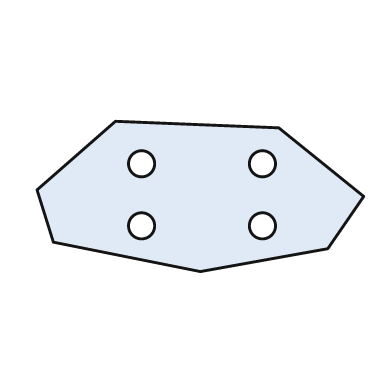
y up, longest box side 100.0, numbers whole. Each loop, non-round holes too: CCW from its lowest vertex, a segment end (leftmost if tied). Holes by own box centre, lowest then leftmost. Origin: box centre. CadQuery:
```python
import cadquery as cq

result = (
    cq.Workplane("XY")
    .moveTo(0.0, -23.0)
    .lineTo(39.0, -16.0)
    .lineTo(50.0, 0.0)
    .lineTo(24.0, 21.0)
    .lineTo(-26.0, 23.0)
    .lineTo(-50.0, 2.0)
    .lineTo(-45.0, -14.0)
    .close()
    .moveTo(-18.0, -9.0)
    .circle(4.0)
    .moveTo(19.0, -9.0)
    .circle(4.0)
    .moveTo(-18.0, 10.0)
    .circle(4.0)
    .moveTo(19.0, 10.0)
    .circle(4.0)
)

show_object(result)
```